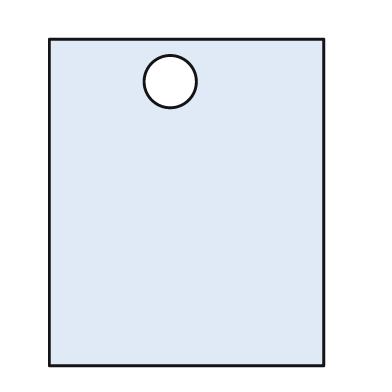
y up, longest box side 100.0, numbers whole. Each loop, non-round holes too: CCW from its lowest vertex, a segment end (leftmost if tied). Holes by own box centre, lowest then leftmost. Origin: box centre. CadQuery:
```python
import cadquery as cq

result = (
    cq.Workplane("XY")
    .moveTo(-42.0, -50.0)
    .lineTo(42.0, -50.0)
    .lineTo(42.0, 50.0)
    .lineTo(-42.0, 50.0)
    .close()
    .moveTo(-5.0, 37.0)
    .circle(8.0)
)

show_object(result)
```